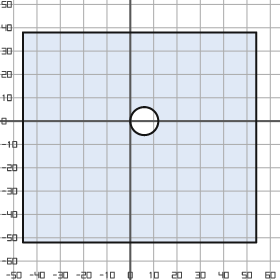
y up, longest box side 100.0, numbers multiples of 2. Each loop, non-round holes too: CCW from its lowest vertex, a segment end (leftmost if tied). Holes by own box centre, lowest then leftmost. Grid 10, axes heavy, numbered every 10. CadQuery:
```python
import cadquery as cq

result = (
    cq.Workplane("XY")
    .moveTo(-46.0, -52.0)
    .lineTo(54.0, -52.0)
    .lineTo(54.0, 38.0)
    .lineTo(-46.0, 38.0)
    .close()
    .moveTo(6.0, 0.0)
    .circle(6.0)
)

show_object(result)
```